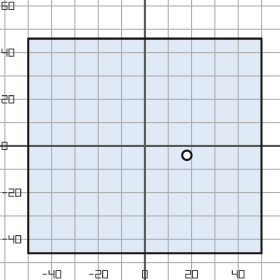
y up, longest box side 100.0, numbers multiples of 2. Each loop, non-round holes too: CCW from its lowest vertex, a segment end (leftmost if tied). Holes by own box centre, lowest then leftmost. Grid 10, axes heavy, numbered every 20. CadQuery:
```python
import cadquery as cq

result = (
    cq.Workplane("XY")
    .moveTo(-50.0, -46.0)
    .lineTo(50.0, -46.0)
    .lineTo(50.0, 46.0)
    .lineTo(-50.0, 46.0)
    .close()
    .moveTo(18.0, -4.0)
    .circle(2.0)
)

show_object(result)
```